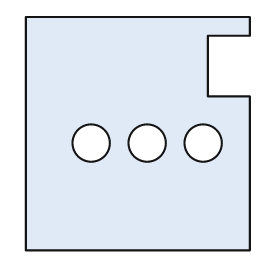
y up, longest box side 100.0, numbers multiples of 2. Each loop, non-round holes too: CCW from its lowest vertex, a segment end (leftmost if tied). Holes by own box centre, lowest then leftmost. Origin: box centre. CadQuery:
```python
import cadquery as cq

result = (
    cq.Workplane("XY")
    .moveTo(-48.0, -50.0)
    .lineTo(48.0, -50.0)
    .lineTo(48.0, 16.0)
    .lineTo(30.0, 16.0)
    .lineTo(30.0, 42.0)
    .lineTo(48.0, 42.0)
    .lineTo(48.0, 50.0)
    .lineTo(-48.0, 50.0)
    .close()
    .moveTo(-20.0, -4.0)
    .circle(8.0)
    .moveTo(4.0, -4.0)
    .circle(8.0)
    .moveTo(28.0, -4.0)
    .circle(8.0)
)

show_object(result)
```